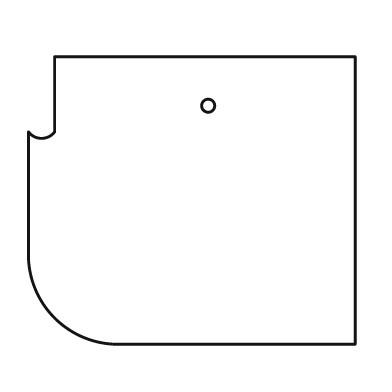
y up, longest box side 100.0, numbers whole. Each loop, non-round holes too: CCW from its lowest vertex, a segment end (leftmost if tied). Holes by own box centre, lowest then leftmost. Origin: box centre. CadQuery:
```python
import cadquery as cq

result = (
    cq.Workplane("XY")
    .moveTo(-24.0, -44.0)
    .lineTo(50.0, -44.0)
    .lineTo(50.0, 44.0)
    .lineTo(-42.0, 44.0)
    .lineTo(-42.0, 21.0)
    .threePointArc((-46.0, 19.0), (-50.0, 21.0))
    .lineTo(-50.0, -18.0)
    .threePointArc((-42.0, -36.0), (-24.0, -44.0))
    .close()
    .moveTo(5.0, 29.0)
    .circle(2.0)
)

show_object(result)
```